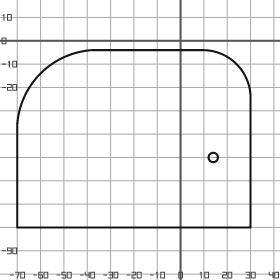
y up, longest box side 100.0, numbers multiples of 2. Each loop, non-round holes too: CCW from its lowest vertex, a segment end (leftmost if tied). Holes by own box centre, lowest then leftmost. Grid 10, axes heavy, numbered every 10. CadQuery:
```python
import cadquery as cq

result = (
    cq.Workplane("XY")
    .moveTo(-70.0, -80.0)
    .lineTo(30.0, -80.0)
    .lineTo(30.0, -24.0)
    .threePointArc((24.0, -10.0), (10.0, -4.0))
    .lineTo(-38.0, -4.0)
    .threePointArc((-60.0, -14.0), (-70.0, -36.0))
    .close()
    .moveTo(14.0, -50.0)
    .circle(2.0)
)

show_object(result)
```